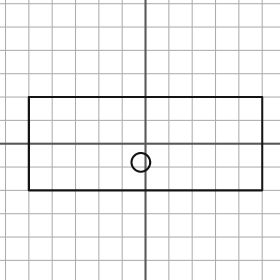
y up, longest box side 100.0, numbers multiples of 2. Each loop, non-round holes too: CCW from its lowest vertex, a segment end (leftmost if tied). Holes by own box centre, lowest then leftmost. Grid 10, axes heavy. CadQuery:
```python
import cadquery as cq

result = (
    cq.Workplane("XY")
    .moveTo(-50.0, -20.0)
    .lineTo(50.0, -20.0)
    .lineTo(50.0, 20.0)
    .lineTo(-50.0, 20.0)
    .close()
    .moveTo(-2.0, -8.0)
    .circle(4.0)
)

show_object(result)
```